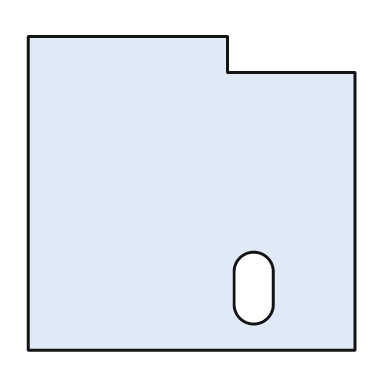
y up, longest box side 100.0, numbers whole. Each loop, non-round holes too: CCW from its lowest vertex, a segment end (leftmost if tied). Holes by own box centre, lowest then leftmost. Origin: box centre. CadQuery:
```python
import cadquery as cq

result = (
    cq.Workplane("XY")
    .moveTo(-50.0, -48.0)
    .lineTo(50.0, -48.0)
    .lineTo(50.0, 37.0)
    .lineTo(11.0, 37.0)
    .lineTo(11.0, 48.0)
    .lineTo(-50.0, 48.0)
    .close()
    .moveTo(13.0, -34.0)
    .threePointArc((19.0, -40.0), (25.0, -34.0))
    .lineTo(25.0, -24.0)
    .threePointArc((19.0, -18.0), (13.0, -24.0))
    .close()
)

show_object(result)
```